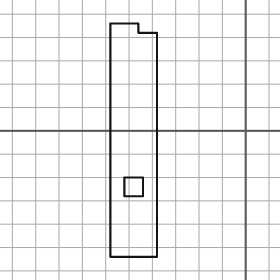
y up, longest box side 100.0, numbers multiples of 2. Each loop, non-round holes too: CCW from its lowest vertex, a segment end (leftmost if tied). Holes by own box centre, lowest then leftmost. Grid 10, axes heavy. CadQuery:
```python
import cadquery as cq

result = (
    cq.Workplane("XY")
    .moveTo(-58.0, -54.0)
    .lineTo(-38.0, -54.0)
    .lineTo(-38.0, 42.0)
    .lineTo(-46.0, 42.0)
    .lineTo(-46.0, 46.0)
    .lineTo(-58.0, 46.0)
    .close()
    .moveTo(-52.0, -28.0)
    .lineTo(-44.0, -28.0)
    .lineTo(-44.0, -20.0)
    .lineTo(-52.0, -20.0)
    .close()
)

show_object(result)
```